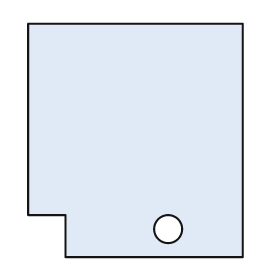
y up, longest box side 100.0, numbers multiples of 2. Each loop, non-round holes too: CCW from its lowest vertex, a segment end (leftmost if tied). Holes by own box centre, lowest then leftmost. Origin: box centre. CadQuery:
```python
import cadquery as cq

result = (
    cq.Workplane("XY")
    .moveTo(-30.0, -50.0)
    .lineTo(46.0, -50.0)
    .lineTo(46.0, 50.0)
    .lineTo(-46.0, 50.0)
    .lineTo(-46.0, -32.0)
    .lineTo(-30.0, -32.0)
    .close()
    .moveTo(14.0, -38.0)
    .circle(6.0)
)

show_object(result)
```